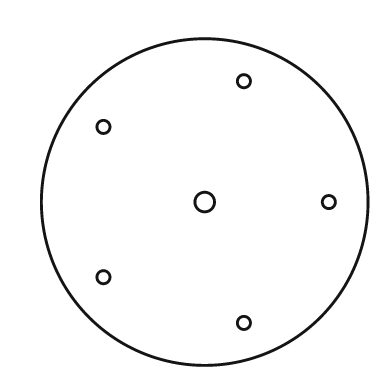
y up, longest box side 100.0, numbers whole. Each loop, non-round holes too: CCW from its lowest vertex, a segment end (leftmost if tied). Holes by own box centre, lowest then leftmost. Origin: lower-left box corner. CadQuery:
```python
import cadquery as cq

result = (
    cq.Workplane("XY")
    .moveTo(50.0, 50.0)
    .circle(50.0)
    .moveTo(62.0, 13.0)
    .circle(2.0)
    .moveTo(19.0, 27.0)
    .circle(2.0)
    .moveTo(50.0, 50.0)
    .circle(3.0)
    .moveTo(88.0, 50.0)
    .circle(2.0)
    .moveTo(19.0, 73.0)
    .circle(2.0)
    .moveTo(62.0, 87.0)
    .circle(2.0)
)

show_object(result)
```